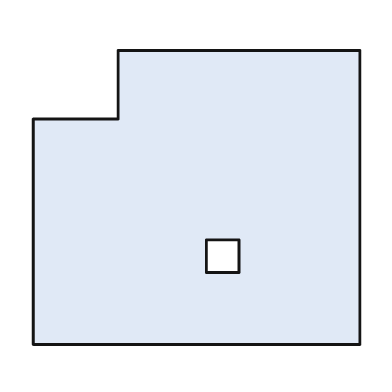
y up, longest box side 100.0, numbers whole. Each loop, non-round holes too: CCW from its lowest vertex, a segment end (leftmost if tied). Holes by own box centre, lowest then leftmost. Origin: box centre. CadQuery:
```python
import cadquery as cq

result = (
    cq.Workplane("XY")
    .moveTo(-50.0, -45.0)
    .lineTo(50.0, -45.0)
    .lineTo(50.0, 45.0)
    .lineTo(-24.0, 45.0)
    .lineTo(-24.0, 24.0)
    .lineTo(-50.0, 24.0)
    .close()
    .moveTo(3.0, -23.0)
    .lineTo(13.0, -23.0)
    .lineTo(13.0, -13.0)
    .lineTo(3.0, -13.0)
    .close()
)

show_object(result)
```